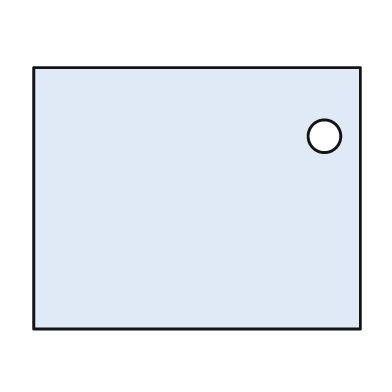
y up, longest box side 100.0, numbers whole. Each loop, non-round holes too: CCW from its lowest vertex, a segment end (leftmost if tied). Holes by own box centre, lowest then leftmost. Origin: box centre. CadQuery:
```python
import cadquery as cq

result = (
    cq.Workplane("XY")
    .moveTo(-50.0, -40.0)
    .lineTo(50.0, -40.0)
    .lineTo(50.0, 40.0)
    .lineTo(-50.0, 40.0)
    .close()
    .moveTo(39.0, 19.0)
    .circle(5.0)
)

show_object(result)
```